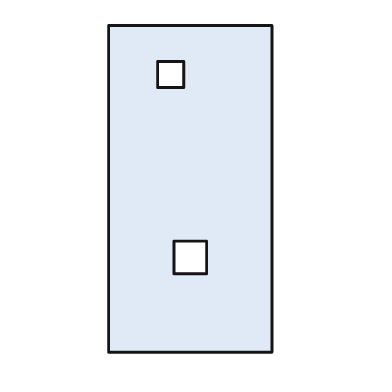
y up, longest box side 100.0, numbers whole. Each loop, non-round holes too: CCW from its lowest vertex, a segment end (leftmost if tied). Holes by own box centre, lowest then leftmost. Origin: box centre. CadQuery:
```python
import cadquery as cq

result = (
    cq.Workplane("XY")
    .moveTo(-25.0, -50.0)
    .lineTo(25.0, -50.0)
    .lineTo(25.0, 50.0)
    .lineTo(-25.0, 50.0)
    .close()
    .moveTo(-5.0, -26.0)
    .lineTo(5.0, -26.0)
    .lineTo(5.0, -16.0)
    .lineTo(-5.0, -16.0)
    .close()
    .moveTo(-10.0, 31.0)
    .lineTo(-2.0, 31.0)
    .lineTo(-2.0, 39.0)
    .lineTo(-10.0, 39.0)
    .close()
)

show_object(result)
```